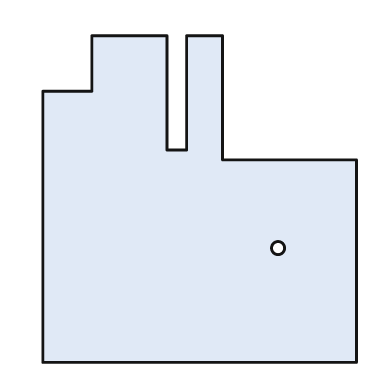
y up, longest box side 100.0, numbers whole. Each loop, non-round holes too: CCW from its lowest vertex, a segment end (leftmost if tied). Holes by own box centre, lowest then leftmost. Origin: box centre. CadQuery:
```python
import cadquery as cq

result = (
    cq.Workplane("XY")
    .moveTo(-48.0, -50.0)
    .lineTo(48.0, -50.0)
    .lineTo(48.0, 12.0)
    .lineTo(7.0, 12.0)
    .lineTo(7.0, 50.0)
    .lineTo(-4.0, 50.0)
    .lineTo(-4.0, 15.0)
    .lineTo(-10.0, 15.0)
    .lineTo(-10.0, 50.0)
    .lineTo(-33.0, 50.0)
    .lineTo(-33.0, 33.0)
    .lineTo(-48.0, 33.0)
    .close()
    .moveTo(24.0, -15.0)
    .circle(2.0)
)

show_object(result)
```